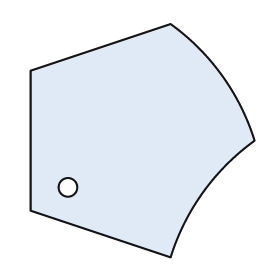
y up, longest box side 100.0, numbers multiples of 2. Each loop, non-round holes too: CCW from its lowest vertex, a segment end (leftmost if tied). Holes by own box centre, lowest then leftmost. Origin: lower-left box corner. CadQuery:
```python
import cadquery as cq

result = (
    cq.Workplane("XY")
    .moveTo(60.0, 0.0)
    .threePointArc((74.0, 28.0), (96.0, 50.0))
    .threePointArc((82.0, 78.0), (60.0, 100.0))
    .lineTo(0.0, 80.0)
    .lineTo(0.0, 20.0)
    .close()
    .moveTo(16.0, 30.0)
    .circle(4.0)
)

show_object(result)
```